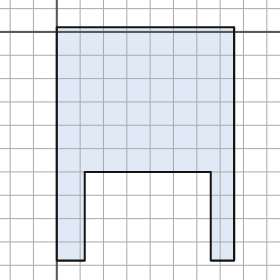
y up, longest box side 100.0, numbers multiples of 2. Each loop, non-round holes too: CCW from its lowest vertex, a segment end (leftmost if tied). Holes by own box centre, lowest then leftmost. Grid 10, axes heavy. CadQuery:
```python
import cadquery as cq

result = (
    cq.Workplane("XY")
    .moveTo(0.0, -98.0)
    .lineTo(12.0, -98.0)
    .lineTo(12.0, -60.0)
    .lineTo(66.0, -60.0)
    .lineTo(66.0, -98.0)
    .lineTo(76.0, -98.0)
    .lineTo(76.0, 2.0)
    .lineTo(0.0, 2.0)
    .close()
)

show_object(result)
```